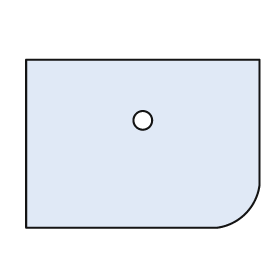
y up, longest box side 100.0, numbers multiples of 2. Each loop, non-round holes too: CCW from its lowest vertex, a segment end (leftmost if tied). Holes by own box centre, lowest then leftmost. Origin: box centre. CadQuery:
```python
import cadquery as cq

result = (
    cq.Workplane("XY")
    .moveTo(-50.0, -36.0)
    .lineTo(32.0, -36.0)
    .threePointArc((44.0, -30.0), (50.0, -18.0))
    .lineTo(50.0, 36.0)
    .lineTo(-50.0, 36.0)
    .close()
    .moveTo(0.0, 10.0)
    .circle(4.0)
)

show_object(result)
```